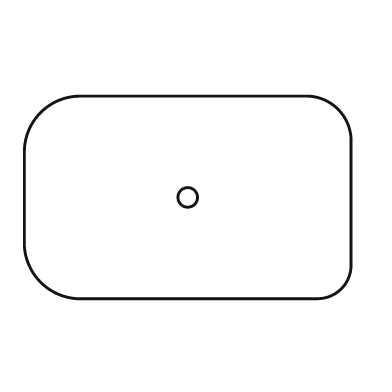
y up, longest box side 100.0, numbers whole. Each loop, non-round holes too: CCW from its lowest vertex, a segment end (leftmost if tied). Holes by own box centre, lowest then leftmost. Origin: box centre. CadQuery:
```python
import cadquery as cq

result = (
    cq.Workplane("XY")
    .moveTo(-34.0, -31.0)
    .lineTo(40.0, -31.0)
    .threePointArc((47.0, -28.0), (50.0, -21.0))
    .lineTo(50.0, 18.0)
    .threePointArc((46.0, 27.0), (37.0, 31.0))
    .lineTo(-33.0, 31.0)
    .threePointArc((-45.0, 26.0), (-50.0, 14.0))
    .lineTo(-50.0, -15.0)
    .threePointArc((-45.0, -26.0), (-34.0, -31.0))
    .close()
    .moveTo(0.0, 0.0)
    .circle(3.0)
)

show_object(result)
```